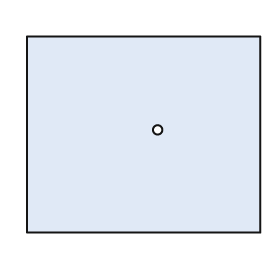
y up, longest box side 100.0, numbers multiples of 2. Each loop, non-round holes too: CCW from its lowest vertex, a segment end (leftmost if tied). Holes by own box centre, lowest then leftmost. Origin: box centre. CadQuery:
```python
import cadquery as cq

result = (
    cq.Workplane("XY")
    .moveTo(-50.0, -42.0)
    .lineTo(50.0, -42.0)
    .lineTo(50.0, 42.0)
    .lineTo(-50.0, 42.0)
    .close()
    .moveTo(6.0, 2.0)
    .circle(2.0)
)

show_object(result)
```